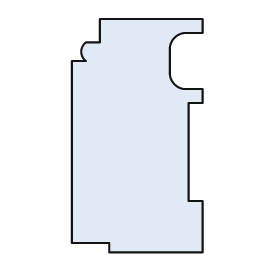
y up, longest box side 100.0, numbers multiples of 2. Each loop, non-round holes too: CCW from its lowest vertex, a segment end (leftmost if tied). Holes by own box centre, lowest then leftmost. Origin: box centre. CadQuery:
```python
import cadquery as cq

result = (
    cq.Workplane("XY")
    .moveTo(-12.0, -50.0)
    .lineTo(28.0, -50.0)
    .lineTo(28.0, -28.0)
    .lineTo(22.0, -28.0)
    .lineTo(22.0, 14.0)
    .lineTo(28.0, 14.0)
    .lineTo(28.0, 20.0)
    .lineTo(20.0, 20.0)
    .threePointArc((16.0, 22.0), (14.0, 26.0))
    .lineTo(14.0, 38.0)
    .threePointArc((16.0, 42.0), (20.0, 44.0))
    .lineTo(28.0, 44.0)
    .lineTo(28.0, 50.0)
    .lineTo(-16.0, 50.0)
    .lineTo(-16.0, 40.0)
    .lineTo(-22.0, 40.0)
    .threePointArc((-24.0, 36.0), (-22.0, 32.0))
    .lineTo(-28.0, 32.0)
    .lineTo(-28.0, -46.0)
    .lineTo(-12.0, -46.0)
    .close()
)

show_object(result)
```